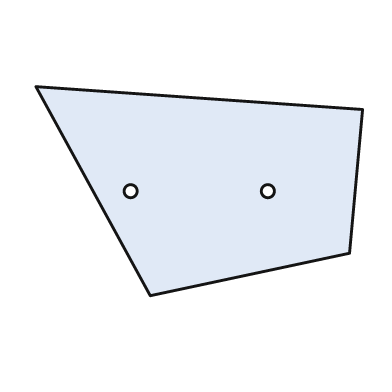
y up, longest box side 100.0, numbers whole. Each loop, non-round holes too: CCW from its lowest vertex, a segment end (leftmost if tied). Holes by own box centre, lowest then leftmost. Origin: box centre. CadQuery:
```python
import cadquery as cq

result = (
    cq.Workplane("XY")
    .moveTo(-15.0, -32.0)
    .lineTo(46.0, -19.0)
    .lineTo(50.0, 25.0)
    .lineTo(-50.0, 32.0)
    .close()
    .moveTo(-21.0, 0.0)
    .circle(2.0)
    .moveTo(21.0, 0.0)
    .circle(2.0)
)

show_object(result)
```